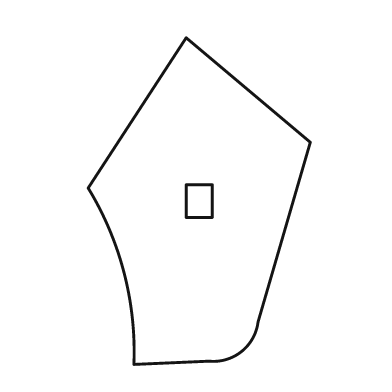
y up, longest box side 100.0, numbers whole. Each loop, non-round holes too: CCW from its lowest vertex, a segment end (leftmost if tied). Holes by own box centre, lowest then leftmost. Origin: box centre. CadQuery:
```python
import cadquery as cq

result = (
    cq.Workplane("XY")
    .moveTo(-20.0, -50.0)
    .lineTo(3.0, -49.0)
    .threePointArc((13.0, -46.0), (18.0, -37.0))
    .lineTo(34.0, 18.0)
    .lineTo(-4.0, 50.0)
    .lineTo(-34.0, 4.0)
    .threePointArc((-23.0, -22.0), (-20.0, -50.0))
    .close()
    .moveTo(-4.0, -5.0)
    .lineTo(4.0, -5.0)
    .lineTo(4.0, 5.0)
    .lineTo(-4.0, 5.0)
    .close()
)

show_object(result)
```